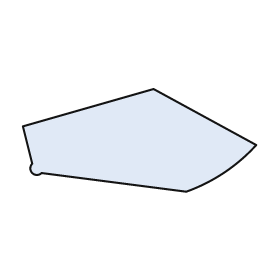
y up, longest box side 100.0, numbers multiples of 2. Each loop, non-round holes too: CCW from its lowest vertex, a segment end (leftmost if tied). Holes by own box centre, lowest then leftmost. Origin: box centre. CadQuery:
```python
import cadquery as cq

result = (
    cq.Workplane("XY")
    .moveTo(20.0, -22.0)
    .threePointArc((36.0, -14.0), (50.0, -2.0))
    .lineTo(6.0, 22.0)
    .lineTo(-50.0, 6.0)
    .lineTo(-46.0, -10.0)
    .threePointArc((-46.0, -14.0), (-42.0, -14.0))
    .close()
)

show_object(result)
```